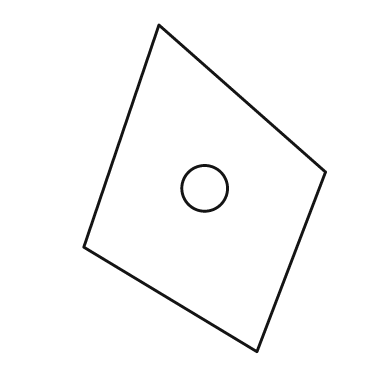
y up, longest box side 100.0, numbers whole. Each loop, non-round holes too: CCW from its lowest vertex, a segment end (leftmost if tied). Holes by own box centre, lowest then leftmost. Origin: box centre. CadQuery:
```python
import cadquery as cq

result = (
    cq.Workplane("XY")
    .moveTo(16.0, -50.0)
    .lineTo(37.0, 5.0)
    .lineTo(-14.0, 50.0)
    .lineTo(-37.0, -18.0)
    .close()
    .moveTo(0.0, 0.0)
    .circle(7.0)
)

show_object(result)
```